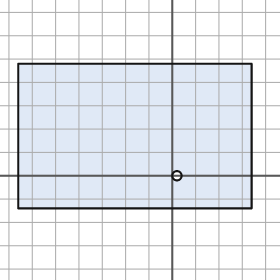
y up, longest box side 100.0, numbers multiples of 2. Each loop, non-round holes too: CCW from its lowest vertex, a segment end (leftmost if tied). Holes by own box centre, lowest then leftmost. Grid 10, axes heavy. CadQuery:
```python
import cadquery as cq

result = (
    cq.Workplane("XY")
    .moveTo(-66.0, -14.0)
    .lineTo(34.0, -14.0)
    .lineTo(34.0, 48.0)
    .lineTo(-66.0, 48.0)
    .close()
    .moveTo(2.0, 0.0)
    .circle(2.0)
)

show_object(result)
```